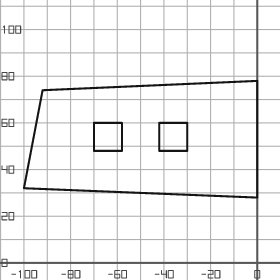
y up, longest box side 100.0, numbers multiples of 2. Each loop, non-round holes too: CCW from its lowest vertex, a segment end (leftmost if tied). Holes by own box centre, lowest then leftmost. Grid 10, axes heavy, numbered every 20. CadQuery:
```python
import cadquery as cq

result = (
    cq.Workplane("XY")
    .moveTo(0.0, 28.0)
    .lineTo(0.0, 78.0)
    .lineTo(-92.0, 74.0)
    .lineTo(-100.0, 32.0)
    .close()
    .moveTo(-70.0, 48.0)
    .lineTo(-58.0, 48.0)
    .lineTo(-58.0, 60.0)
    .lineTo(-70.0, 60.0)
    .close()
    .moveTo(-42.0, 48.0)
    .lineTo(-30.0, 48.0)
    .lineTo(-30.0, 60.0)
    .lineTo(-42.0, 60.0)
    .close()
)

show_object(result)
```